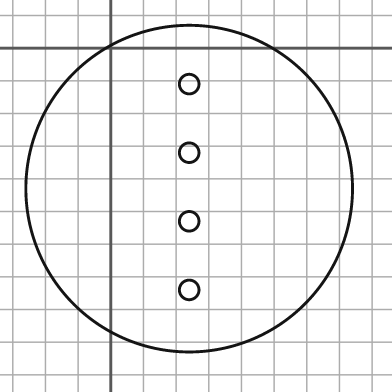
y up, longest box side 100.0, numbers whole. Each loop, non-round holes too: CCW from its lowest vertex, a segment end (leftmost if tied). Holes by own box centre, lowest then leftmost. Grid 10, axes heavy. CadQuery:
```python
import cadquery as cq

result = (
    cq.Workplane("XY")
    .moveTo(24.0, -43.0)
    .circle(50.0)
    .moveTo(24.0, -74.0)
    .circle(3.0)
    .moveTo(24.0, -53.0)
    .circle(3.0)
    .moveTo(24.0, -32.0)
    .circle(3.0)
    .moveTo(24.0, -11.0)
    .circle(3.0)
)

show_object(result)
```